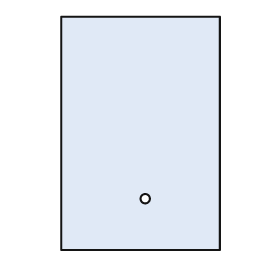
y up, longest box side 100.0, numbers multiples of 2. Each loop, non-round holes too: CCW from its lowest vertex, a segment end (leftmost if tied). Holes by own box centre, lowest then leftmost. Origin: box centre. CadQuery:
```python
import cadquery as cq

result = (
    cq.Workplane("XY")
    .moveTo(-34.0, -50.0)
    .lineTo(34.0, -50.0)
    .lineTo(34.0, 50.0)
    .lineTo(-34.0, 50.0)
    .close()
    .moveTo(2.0, -28.0)
    .circle(2.0)
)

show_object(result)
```